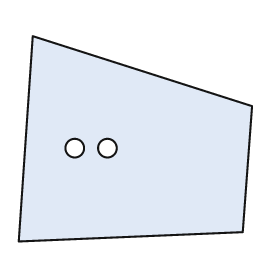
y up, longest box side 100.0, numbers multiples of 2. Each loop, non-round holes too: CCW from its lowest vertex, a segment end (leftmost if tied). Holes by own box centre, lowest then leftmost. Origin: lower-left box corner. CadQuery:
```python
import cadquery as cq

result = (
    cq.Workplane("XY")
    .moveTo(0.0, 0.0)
    .lineTo(96.0, 4.0)
    .lineTo(100.0, 58.0)
    .lineTo(6.0, 88.0)
    .close()
    .moveTo(24.0, 40.0)
    .circle(4.0)
    .moveTo(38.0, 40.0)
    .circle(4.0)
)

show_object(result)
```